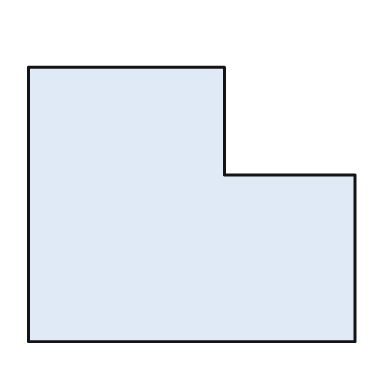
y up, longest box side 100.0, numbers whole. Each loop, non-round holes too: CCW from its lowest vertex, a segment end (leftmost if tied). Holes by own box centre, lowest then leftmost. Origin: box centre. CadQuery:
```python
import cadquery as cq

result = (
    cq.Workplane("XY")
    .moveTo(-50.0, -42.0)
    .lineTo(50.0, -42.0)
    .lineTo(50.0, 9.0)
    .lineTo(10.0, 9.0)
    .lineTo(10.0, 42.0)
    .lineTo(-50.0, 42.0)
    .close()
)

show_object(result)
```